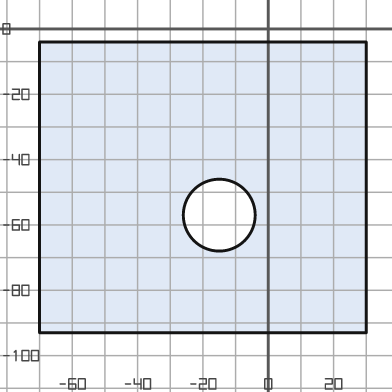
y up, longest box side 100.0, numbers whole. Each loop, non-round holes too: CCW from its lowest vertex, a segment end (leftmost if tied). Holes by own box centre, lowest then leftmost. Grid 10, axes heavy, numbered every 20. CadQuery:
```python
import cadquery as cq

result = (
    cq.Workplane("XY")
    .moveTo(-70.0, -93.0)
    .lineTo(30.0, -93.0)
    .lineTo(30.0, -4.0)
    .lineTo(-70.0, -4.0)
    .close()
    .moveTo(-15.0, -57.0)
    .circle(11.0)
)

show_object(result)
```